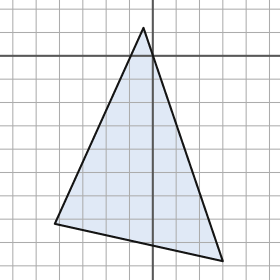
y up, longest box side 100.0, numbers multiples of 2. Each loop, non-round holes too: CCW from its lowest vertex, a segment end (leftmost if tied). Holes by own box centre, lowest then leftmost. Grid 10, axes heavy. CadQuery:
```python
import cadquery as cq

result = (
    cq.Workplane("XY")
    .moveTo(30.0, -88.0)
    .lineTo(-4.0, 12.0)
    .lineTo(-42.0, -72.0)
    .close()
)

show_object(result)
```